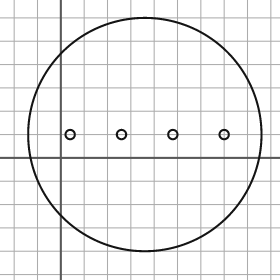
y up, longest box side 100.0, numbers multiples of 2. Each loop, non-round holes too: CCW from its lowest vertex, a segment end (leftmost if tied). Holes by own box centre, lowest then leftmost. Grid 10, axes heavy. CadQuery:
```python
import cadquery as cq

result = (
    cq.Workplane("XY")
    .moveTo(36.0, 10.0)
    .circle(50.0)
    .moveTo(4.0, 10.0)
    .circle(2.0)
    .moveTo(26.0, 10.0)
    .circle(2.0)
    .moveTo(48.0, 10.0)
    .circle(2.0)
    .moveTo(70.0, 10.0)
    .circle(2.0)
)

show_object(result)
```